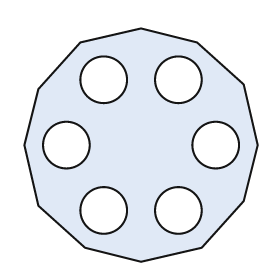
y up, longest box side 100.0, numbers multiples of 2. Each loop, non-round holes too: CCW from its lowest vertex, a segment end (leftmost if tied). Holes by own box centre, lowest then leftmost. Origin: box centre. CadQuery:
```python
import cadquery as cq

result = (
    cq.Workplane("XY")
    .moveTo(0.0, -50.0)
    .lineTo(26.0, -44.0)
    .lineTo(44.0, -24.0)
    .lineTo(50.0, 0.0)
    .lineTo(44.0, 26.0)
    .lineTo(24.0, 44.0)
    .lineTo(0.0, 50.0)
    .lineTo(-26.0, 44.0)
    .lineTo(-44.0, 24.0)
    .lineTo(-50.0, 0.0)
    .lineTo(-44.0, -26.0)
    .lineTo(-24.0, -44.0)
    .close()
    .moveTo(-16.0, -28.0)
    .circle(10.0)
    .moveTo(16.0, -28.0)
    .circle(10.0)
    .moveTo(-32.0, 0.0)
    .circle(10.0)
    .moveTo(32.0, 0.0)
    .circle(10.0)
    .moveTo(-16.0, 28.0)
    .circle(10.0)
    .moveTo(16.0, 28.0)
    .circle(10.0)
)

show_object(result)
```